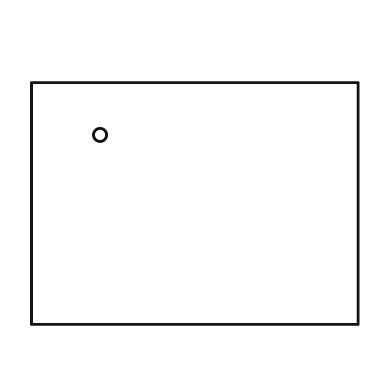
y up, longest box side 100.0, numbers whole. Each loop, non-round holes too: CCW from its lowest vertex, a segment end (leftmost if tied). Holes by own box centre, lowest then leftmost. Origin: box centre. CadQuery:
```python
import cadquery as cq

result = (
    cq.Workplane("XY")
    .moveTo(-50.0, -37.0)
    .lineTo(50.0, -37.0)
    .lineTo(50.0, 37.0)
    .lineTo(-50.0, 37.0)
    .close()
    .moveTo(-29.0, 21.0)
    .circle(2.0)
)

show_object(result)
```